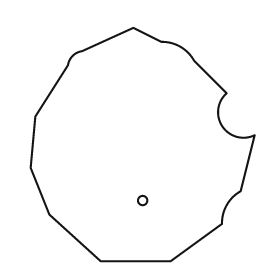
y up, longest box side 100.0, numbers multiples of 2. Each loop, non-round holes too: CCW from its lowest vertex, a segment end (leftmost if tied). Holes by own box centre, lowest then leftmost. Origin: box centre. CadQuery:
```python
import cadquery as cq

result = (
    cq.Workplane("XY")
    .moveTo(-18.0, -50.0)
    .lineTo(12.0, -50.0)
    .lineTo(34.0, -34.0)
    .threePointArc((36.0, -26.0), (42.0, -20.0))
    .lineTo(48.0, 4.0)
    .threePointArc((34.0, 8.0), (36.0, 22.0))
    .lineTo(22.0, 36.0)
    .threePointArc((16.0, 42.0), (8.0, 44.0))
    .lineTo(-4.0, 50.0)
    .lineTo(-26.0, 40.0)
    .threePointArc((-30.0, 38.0), (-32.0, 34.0))
    .lineTo(-46.0, 12.0)
    .lineTo(-48.0, -10.0)
    .lineTo(-40.0, -30.0)
    .close()
    .moveTo(0.0, -24.0)
    .circle(2.0)
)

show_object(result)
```